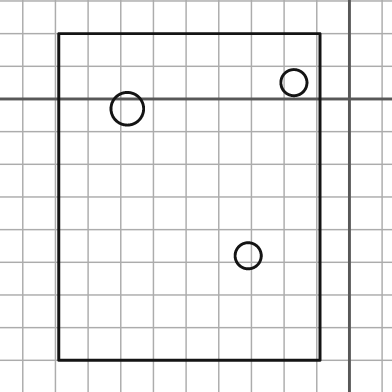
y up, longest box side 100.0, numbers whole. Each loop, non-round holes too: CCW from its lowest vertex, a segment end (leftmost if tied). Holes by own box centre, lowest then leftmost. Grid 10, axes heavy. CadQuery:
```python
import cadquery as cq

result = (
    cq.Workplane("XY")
    .moveTo(-89.0, -80.0)
    .lineTo(-9.0, -80.0)
    .lineTo(-9.0, 20.0)
    .lineTo(-89.0, 20.0)
    .close()
    .moveTo(-31.0, -48.0)
    .circle(4.0)
    .moveTo(-68.0, -3.0)
    .circle(5.0)
    .moveTo(-17.0, 5.0)
    .circle(4.0)
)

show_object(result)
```